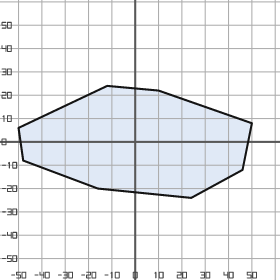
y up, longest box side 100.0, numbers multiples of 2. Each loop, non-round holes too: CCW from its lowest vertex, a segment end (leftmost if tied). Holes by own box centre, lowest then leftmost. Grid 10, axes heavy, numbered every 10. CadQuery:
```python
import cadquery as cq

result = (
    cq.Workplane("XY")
    .moveTo(24.0, -24.0)
    .lineTo(46.0, -12.0)
    .lineTo(50.0, 8.0)
    .lineTo(10.0, 22.0)
    .lineTo(-12.0, 24.0)
    .lineTo(-50.0, 6.0)
    .lineTo(-48.0, -8.0)
    .lineTo(-16.0, -20.0)
    .close()
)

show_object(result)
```